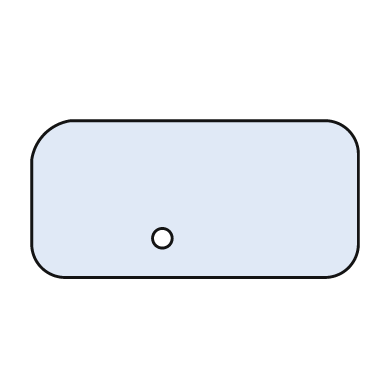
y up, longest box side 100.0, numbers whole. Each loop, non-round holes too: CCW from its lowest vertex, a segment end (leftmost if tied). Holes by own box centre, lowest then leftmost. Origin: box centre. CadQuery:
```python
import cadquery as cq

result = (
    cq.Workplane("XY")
    .moveTo(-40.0, -24.0)
    .lineTo(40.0, -24.0)
    .threePointArc((47.0, -21.0), (50.0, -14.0))
    .lineTo(50.0, 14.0)
    .threePointArc((47.0, 21.0), (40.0, 24.0))
    .lineTo(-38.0, 24.0)
    .threePointArc((-46.0, 20.0), (-50.0, 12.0))
    .lineTo(-50.0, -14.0)
    .threePointArc((-47.0, -21.0), (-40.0, -24.0))
    .close()
    .moveTo(-10.0, -12.0)
    .circle(3.0)
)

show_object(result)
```